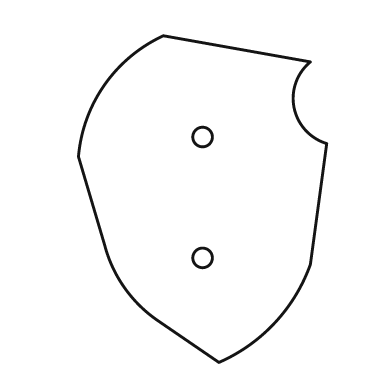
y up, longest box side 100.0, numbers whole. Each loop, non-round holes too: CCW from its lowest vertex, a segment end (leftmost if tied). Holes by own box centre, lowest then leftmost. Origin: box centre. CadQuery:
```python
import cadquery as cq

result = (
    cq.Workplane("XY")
    .moveTo(5.0, -50.0)
    .threePointArc((22.0, -38.0), (33.0, -20.0))
    .lineTo(38.0, 17.0)
    .threePointArc((28.0, 28.0), (33.0, 42.0))
    .lineTo(-12.0, 50.0)
    .threePointArc((-30.0, 35.0), (-38.0, 13.0))
    .lineTo(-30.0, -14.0)
    .threePointArc((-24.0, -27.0), (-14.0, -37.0))
    .close()
    .moveTo(0.0, -18.0)
    .circle(3.0)
    .moveTo(0.0, 19.0)
    .circle(3.0)
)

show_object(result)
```